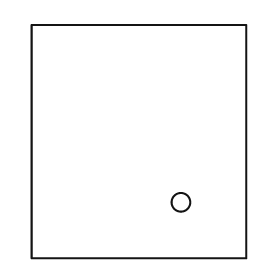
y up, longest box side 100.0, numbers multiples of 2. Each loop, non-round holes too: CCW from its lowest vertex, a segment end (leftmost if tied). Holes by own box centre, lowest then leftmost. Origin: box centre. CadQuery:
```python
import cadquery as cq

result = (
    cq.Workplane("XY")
    .moveTo(-46.0, -50.0)
    .lineTo(46.0, -50.0)
    .lineTo(46.0, 50.0)
    .lineTo(-46.0, 50.0)
    .close()
    .moveTo(18.0, -26.0)
    .circle(4.0)
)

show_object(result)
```